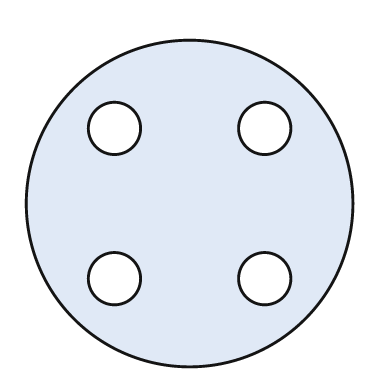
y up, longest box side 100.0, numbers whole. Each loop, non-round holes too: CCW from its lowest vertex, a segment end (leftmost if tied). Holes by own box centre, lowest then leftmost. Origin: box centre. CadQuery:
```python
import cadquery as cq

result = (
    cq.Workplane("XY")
    .moveTo(0.0, 0.0)
    .circle(50.0)
    .moveTo(-23.0, -23.0)
    .circle(8.0)
    .moveTo(23.0, -23.0)
    .circle(8.0)
    .moveTo(-23.0, 23.0)
    .circle(8.0)
    .moveTo(23.0, 23.0)
    .circle(8.0)
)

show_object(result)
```